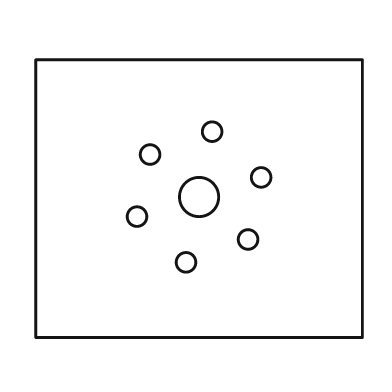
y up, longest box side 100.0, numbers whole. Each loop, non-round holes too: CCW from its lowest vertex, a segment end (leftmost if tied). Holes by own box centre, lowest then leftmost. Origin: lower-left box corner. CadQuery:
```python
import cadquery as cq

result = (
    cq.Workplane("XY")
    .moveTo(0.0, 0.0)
    .lineTo(100.0, 0.0)
    .lineTo(100.0, 85.0)
    .lineTo(0.0, 85.0)
    .close()
    .moveTo(46.0, 23.0)
    .circle(3.0)
    .moveTo(65.0, 30.0)
    .circle(3.0)
    .moveTo(31.0, 37.0)
    .circle(3.0)
    .moveTo(50.0, 43.0)
    .circle(6.0)
    .moveTo(69.0, 49.0)
    .circle(3.0)
    .moveTo(35.0, 56.0)
    .circle(3.0)
    .moveTo(54.0, 63.0)
    .circle(3.0)
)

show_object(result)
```